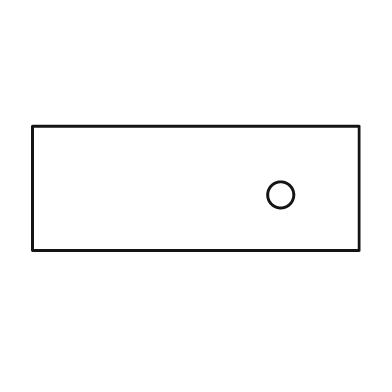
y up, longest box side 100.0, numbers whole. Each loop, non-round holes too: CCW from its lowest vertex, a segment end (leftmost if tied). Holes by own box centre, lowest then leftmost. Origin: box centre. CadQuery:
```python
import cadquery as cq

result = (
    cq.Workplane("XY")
    .moveTo(-50.0, -19.0)
    .lineTo(50.0, -19.0)
    .lineTo(50.0, 19.0)
    .lineTo(-50.0, 19.0)
    .close()
    .moveTo(26.0, -2.0)
    .circle(4.0)
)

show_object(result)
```